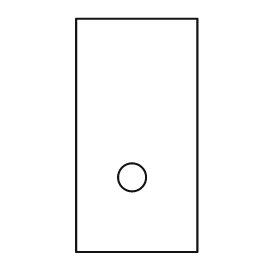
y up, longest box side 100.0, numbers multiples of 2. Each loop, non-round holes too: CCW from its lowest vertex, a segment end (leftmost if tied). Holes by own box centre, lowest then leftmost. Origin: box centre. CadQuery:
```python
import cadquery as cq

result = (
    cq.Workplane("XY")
    .moveTo(-26.0, -50.0)
    .lineTo(26.0, -50.0)
    .lineTo(26.0, 50.0)
    .lineTo(-26.0, 50.0)
    .close()
    .moveTo(-2.0, -18.0)
    .circle(6.0)
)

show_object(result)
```